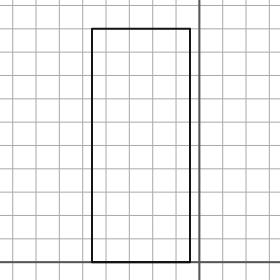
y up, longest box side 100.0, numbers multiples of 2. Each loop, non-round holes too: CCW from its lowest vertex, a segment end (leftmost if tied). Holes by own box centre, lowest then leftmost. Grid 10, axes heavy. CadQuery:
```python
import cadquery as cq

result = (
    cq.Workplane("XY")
    .moveTo(-46.0, 0.0)
    .lineTo(-4.0, 0.0)
    .lineTo(-4.0, 100.0)
    .lineTo(-46.0, 100.0)
    .close()
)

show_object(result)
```